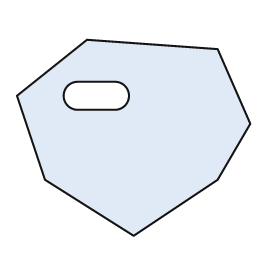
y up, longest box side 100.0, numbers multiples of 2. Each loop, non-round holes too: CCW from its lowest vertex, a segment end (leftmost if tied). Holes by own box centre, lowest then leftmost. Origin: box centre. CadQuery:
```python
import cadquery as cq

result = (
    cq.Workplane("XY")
    .moveTo(0.0, -42.0)
    .lineTo(36.0, -18.0)
    .lineTo(50.0, 6.0)
    .lineTo(36.0, 38.0)
    .lineTo(-20.0, 42.0)
    .lineTo(-50.0, 18.0)
    .lineTo(-38.0, -18.0)
    .close()
    .moveTo(-24.0, 12.0)
    .lineTo(-8.0, 12.0)
    .threePointArc((-2.0, 18.0), (-8.0, 24.0))
    .lineTo(-24.0, 24.0)
    .threePointArc((-30.0, 18.0), (-24.0, 12.0))
    .close()
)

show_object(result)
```